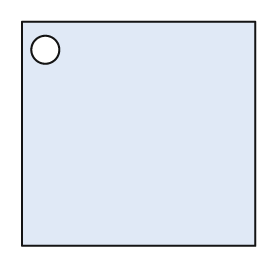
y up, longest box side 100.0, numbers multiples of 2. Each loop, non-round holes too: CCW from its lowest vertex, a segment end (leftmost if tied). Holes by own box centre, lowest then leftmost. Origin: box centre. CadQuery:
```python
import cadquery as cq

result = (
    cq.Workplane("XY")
    .moveTo(-50.0, -48.0)
    .lineTo(50.0, -48.0)
    .lineTo(50.0, 48.0)
    .lineTo(-50.0, 48.0)
    .close()
    .moveTo(-40.0, 36.0)
    .circle(6.0)
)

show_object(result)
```